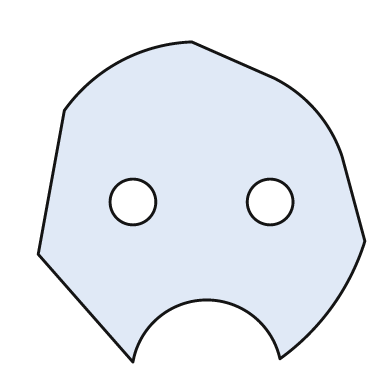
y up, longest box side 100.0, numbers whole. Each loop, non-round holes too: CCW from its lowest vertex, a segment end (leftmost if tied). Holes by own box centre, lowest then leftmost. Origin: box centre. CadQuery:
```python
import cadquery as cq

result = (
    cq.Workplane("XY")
    .moveTo(-21.0, -49.0)
    .threePointArc((1.0, -30.0), (24.0, -48.0))
    .threePointArc((40.0, -32.0), (50.0, -12.0))
    .lineTo(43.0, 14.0)
    .threePointArc((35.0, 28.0), (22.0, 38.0))
    .lineTo(-3.0, 49.0)
    .threePointArc((-25.0, 43.0), (-42.0, 28.0))
    .lineTo(-50.0, -16.0)
    .close()
    .moveTo(-21.0, 0.0)
    .circle(7.0)
    .moveTo(21.0, 0.0)
    .circle(7.0)
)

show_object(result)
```